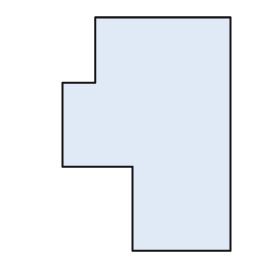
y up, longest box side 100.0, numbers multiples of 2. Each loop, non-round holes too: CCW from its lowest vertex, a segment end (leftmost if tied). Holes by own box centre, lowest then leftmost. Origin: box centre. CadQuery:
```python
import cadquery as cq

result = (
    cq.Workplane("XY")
    .moveTo(-6.0, -50.0)
    .lineTo(36.0, -50.0)
    .lineTo(36.0, 50.0)
    .lineTo(-22.0, 50.0)
    .lineTo(-22.0, 22.0)
    .lineTo(-36.0, 22.0)
    .lineTo(-36.0, -14.0)
    .lineTo(-6.0, -14.0)
    .close()
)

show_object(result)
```